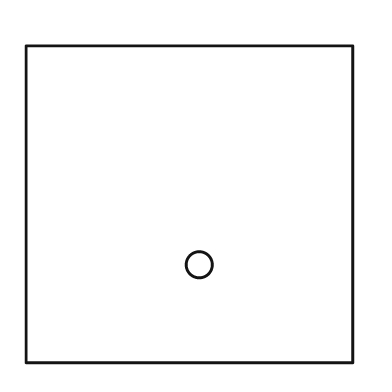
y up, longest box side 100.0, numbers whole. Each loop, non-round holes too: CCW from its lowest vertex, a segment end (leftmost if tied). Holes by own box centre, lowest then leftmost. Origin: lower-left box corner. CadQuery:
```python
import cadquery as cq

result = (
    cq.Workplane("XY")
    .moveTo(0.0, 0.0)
    .lineTo(100.0, 0.0)
    .lineTo(100.0, 97.0)
    .lineTo(0.0, 97.0)
    .close()
    .moveTo(53.0, 30.0)
    .circle(4.0)
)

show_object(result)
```